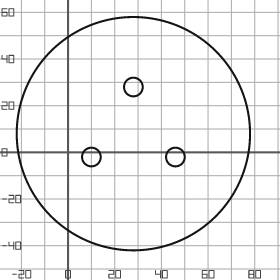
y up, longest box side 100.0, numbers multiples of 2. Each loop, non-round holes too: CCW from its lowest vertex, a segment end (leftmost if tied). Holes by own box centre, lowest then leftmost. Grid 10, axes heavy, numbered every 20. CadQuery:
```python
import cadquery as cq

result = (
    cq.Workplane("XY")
    .moveTo(28.0, 8.0)
    .circle(50.0)
    .moveTo(10.0, -2.0)
    .circle(4.0)
    .moveTo(46.0, -2.0)
    .circle(4.0)
    .moveTo(28.0, 28.0)
    .circle(4.0)
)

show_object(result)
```